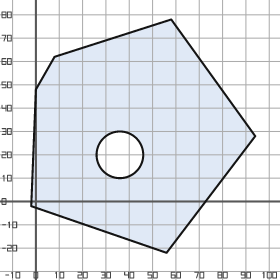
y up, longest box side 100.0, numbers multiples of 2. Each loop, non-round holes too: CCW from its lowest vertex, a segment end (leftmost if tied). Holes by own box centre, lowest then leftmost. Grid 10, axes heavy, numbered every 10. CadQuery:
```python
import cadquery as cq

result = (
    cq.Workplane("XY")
    .moveTo(56.0, -22.0)
    .lineTo(94.0, 28.0)
    .lineTo(58.0, 78.0)
    .lineTo(8.0, 62.0)
    .lineTo(0.0, 48.0)
    .lineTo(-2.0, -2.0)
    .close()
    .moveTo(36.0, 20.0)
    .circle(10.0)
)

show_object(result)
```